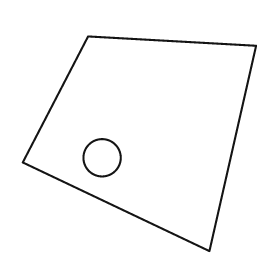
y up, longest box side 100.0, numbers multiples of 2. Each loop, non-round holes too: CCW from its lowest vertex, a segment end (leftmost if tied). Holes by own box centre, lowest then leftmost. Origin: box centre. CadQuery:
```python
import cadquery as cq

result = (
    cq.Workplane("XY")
    .moveTo(30.0, -46.0)
    .lineTo(50.0, 42.0)
    .lineTo(-22.0, 46.0)
    .lineTo(-50.0, -8.0)
    .close()
    .moveTo(-16.0, -6.0)
    .circle(8.0)
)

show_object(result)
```